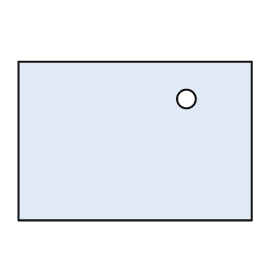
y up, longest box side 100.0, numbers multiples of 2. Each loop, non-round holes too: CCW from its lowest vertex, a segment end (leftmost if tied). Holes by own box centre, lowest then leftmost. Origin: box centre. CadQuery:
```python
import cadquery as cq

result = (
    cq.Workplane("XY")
    .moveTo(-50.0, -34.0)
    .lineTo(50.0, -34.0)
    .lineTo(50.0, 34.0)
    .lineTo(-50.0, 34.0)
    .close()
    .moveTo(22.0, 18.0)
    .circle(4.0)
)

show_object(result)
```